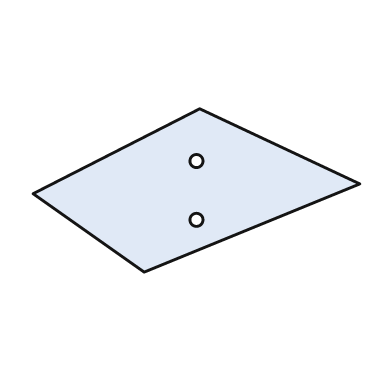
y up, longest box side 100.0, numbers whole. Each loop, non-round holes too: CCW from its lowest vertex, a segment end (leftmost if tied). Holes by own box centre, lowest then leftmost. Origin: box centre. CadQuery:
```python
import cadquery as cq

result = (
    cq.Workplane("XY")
    .moveTo(-16.0, -25.0)
    .lineTo(50.0, 2.0)
    .lineTo(1.0, 25.0)
    .lineTo(-50.0, -1.0)
    .close()
    .moveTo(0.0, -9.0)
    .circle(2.0)
    .moveTo(0.0, 9.0)
    .circle(2.0)
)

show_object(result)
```